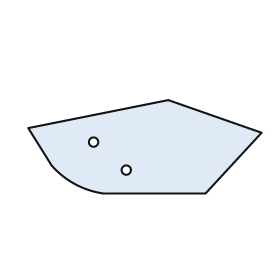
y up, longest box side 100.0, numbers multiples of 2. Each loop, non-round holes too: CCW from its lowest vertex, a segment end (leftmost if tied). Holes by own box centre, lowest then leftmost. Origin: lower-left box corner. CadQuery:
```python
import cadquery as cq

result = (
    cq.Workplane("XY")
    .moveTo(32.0, 0.0)
    .lineTo(76.0, 0.0)
    .lineTo(100.0, 26.0)
    .lineTo(60.0, 40.0)
    .lineTo(0.0, 28.0)
    .lineTo(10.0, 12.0)
    .threePointArc((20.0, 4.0), (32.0, 0.0))
    .close()
    .moveTo(42.0, 10.0)
    .circle(2.0)
    .moveTo(28.0, 22.0)
    .circle(2.0)
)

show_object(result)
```